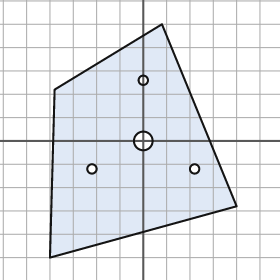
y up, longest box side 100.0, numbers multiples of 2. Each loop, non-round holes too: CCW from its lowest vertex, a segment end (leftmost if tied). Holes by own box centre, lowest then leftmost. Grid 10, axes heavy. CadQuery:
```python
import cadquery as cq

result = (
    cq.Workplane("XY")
    .moveTo(-40.0, -50.0)
    .lineTo(40.0, -28.0)
    .lineTo(8.0, 50.0)
    .lineTo(-38.0, 22.0)
    .close()
    .moveTo(-22.0, -12.0)
    .circle(2.0)
    .moveTo(22.0, -12.0)
    .circle(2.0)
    .moveTo(0.0, 0.0)
    .circle(4.0)
    .moveTo(0.0, 26.0)
    .circle(2.0)
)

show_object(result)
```